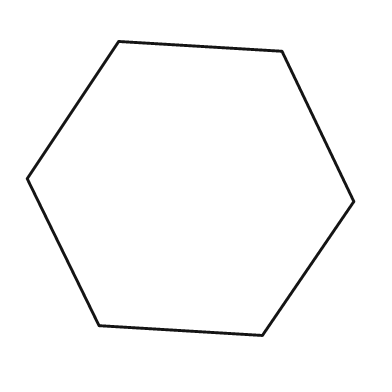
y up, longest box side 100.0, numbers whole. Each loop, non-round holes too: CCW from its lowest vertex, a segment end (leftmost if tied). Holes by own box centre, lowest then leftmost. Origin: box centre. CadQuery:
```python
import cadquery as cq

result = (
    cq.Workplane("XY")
    .moveTo(22.0, -45.0)
    .lineTo(50.0, -4.0)
    .lineTo(28.0, 42.0)
    .lineTo(-22.0, 45.0)
    .lineTo(-50.0, 3.0)
    .lineTo(-28.0, -42.0)
    .close()
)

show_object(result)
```